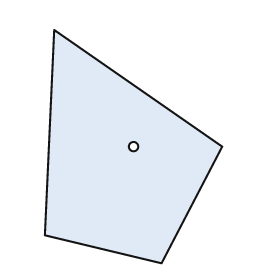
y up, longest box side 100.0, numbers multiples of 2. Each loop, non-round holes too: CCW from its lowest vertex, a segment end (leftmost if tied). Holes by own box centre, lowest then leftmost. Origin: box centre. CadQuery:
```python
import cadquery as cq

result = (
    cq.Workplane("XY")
    .moveTo(12.0, -50.0)
    .lineTo(38.0, 0.0)
    .lineTo(-34.0, 50.0)
    .lineTo(-38.0, -38.0)
    .close()
    .moveTo(0.0, 0.0)
    .circle(2.0)
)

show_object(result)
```